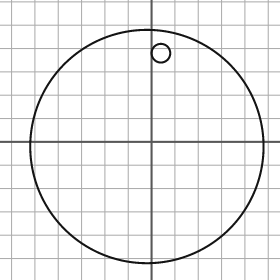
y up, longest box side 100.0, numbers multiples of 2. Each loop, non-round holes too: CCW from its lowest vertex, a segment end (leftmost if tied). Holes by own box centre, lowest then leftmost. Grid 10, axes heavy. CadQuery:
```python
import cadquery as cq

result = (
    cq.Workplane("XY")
    .moveTo(-2.0, -2.0)
    .circle(50.0)
    .moveTo(4.0, 38.0)
    .circle(4.0)
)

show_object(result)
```